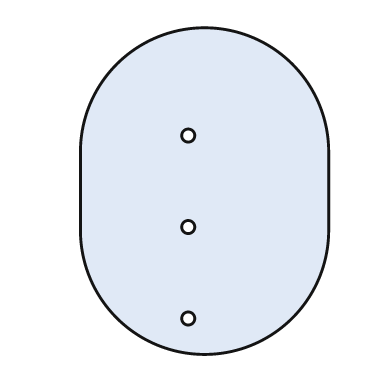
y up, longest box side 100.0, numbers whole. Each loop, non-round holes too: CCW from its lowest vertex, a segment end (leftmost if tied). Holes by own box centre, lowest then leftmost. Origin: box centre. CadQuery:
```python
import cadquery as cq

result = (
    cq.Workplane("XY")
    .moveTo(-38.0, -12.0)
    .threePointArc((0.0, -50.0), (38.0, -12.0))
    .lineTo(38.0, 12.0)
    .threePointArc((0.0, 50.0), (-38.0, 12.0))
    .close()
    .moveTo(-5.0, -39.0)
    .circle(2.0)
    .moveTo(-5.0, -11.0)
    .circle(2.0)
    .moveTo(-5.0, 17.0)
    .circle(2.0)
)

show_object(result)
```